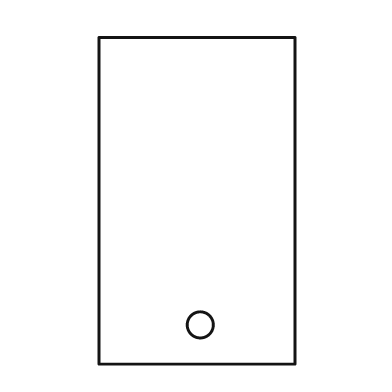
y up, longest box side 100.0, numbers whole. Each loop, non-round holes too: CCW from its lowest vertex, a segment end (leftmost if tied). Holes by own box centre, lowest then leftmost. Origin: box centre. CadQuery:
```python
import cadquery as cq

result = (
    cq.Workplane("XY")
    .moveTo(-30.0, -50.0)
    .lineTo(30.0, -50.0)
    .lineTo(30.0, 50.0)
    .lineTo(-30.0, 50.0)
    .close()
    .moveTo(1.0, -38.0)
    .circle(4.0)
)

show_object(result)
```